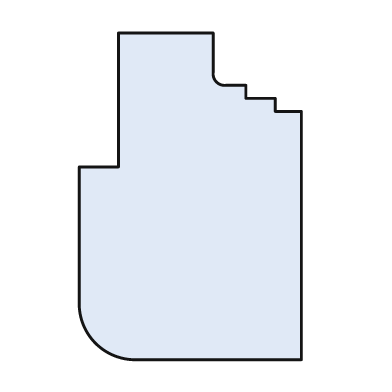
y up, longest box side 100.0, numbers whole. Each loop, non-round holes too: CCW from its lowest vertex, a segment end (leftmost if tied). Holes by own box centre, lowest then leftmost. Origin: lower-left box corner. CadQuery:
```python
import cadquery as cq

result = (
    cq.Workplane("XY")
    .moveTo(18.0, 0.0)
    .lineTo(68.0, 0.0)
    .lineTo(68.0, 76.0)
    .lineTo(60.0, 76.0)
    .lineTo(60.0, 80.0)
    .lineTo(51.0, 80.0)
    .lineTo(51.0, 84.0)
    .lineTo(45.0, 84.0)
    .threePointArc((42.0, 85.0), (41.0, 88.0))
    .lineTo(41.0, 100.0)
    .lineTo(12.0, 100.0)
    .lineTo(12.0, 59.0)
    .lineTo(0.0, 59.0)
    .lineTo(0.0, 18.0)
    .threePointArc((5.0, 5.0), (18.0, 0.0))
    .close()
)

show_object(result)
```